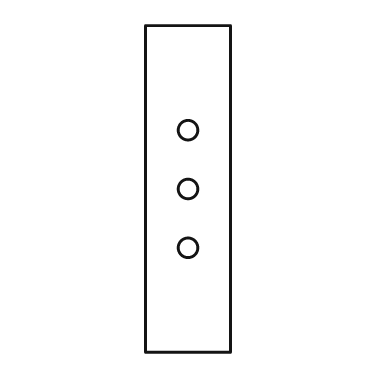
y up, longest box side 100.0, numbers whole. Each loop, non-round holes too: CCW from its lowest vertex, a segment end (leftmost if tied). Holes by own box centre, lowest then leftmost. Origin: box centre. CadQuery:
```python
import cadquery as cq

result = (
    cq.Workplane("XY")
    .moveTo(-13.0, -50.0)
    .lineTo(13.0, -50.0)
    .lineTo(13.0, 50.0)
    .lineTo(-13.0, 50.0)
    .close()
    .moveTo(0.0, -18.0)
    .circle(3.0)
    .moveTo(0.0, 0.0)
    .circle(3.0)
    .moveTo(0.0, 18.0)
    .circle(3.0)
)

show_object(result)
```